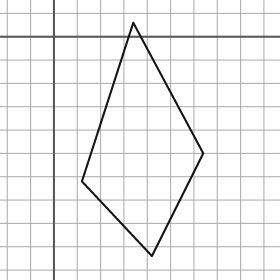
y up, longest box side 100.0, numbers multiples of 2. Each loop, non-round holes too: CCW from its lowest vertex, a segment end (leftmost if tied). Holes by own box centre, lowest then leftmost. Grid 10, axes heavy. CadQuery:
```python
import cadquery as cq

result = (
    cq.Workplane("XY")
    .moveTo(42.0, -94.0)
    .lineTo(64.0, -50.0)
    .lineTo(34.0, 6.0)
    .lineTo(12.0, -62.0)
    .close()
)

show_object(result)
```